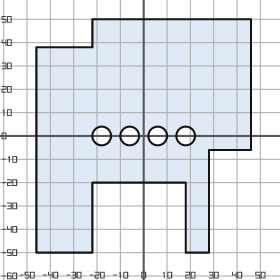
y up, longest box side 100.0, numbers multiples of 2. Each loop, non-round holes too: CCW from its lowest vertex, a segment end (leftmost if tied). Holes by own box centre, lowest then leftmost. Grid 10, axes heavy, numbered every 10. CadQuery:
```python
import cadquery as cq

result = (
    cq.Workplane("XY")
    .moveTo(-46.0, -50.0)
    .lineTo(-22.0, -50.0)
    .lineTo(-22.0, -20.0)
    .lineTo(18.0, -20.0)
    .lineTo(18.0, -50.0)
    .lineTo(28.0, -50.0)
    .lineTo(28.0, -6.0)
    .lineTo(46.0, -6.0)
    .lineTo(46.0, 50.0)
    .lineTo(-22.0, 50.0)
    .lineTo(-22.0, 38.0)
    .lineTo(-46.0, 38.0)
    .close()
    .moveTo(-18.0, 0.0)
    .circle(4.0)
    .moveTo(-6.0, 0.0)
    .circle(4.0)
    .moveTo(6.0, 0.0)
    .circle(4.0)
    .moveTo(18.0, 0.0)
    .circle(4.0)
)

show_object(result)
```